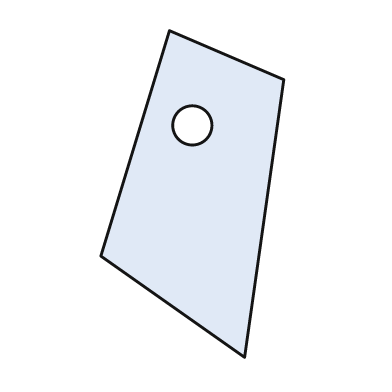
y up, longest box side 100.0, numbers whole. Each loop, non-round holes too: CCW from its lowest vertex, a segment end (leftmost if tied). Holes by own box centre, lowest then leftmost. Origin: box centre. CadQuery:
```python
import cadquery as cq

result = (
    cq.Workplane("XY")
    .moveTo(16.0, -50.0)
    .lineTo(28.0, 35.0)
    .lineTo(-7.0, 50.0)
    .lineTo(-28.0, -19.0)
    .close()
    .moveTo(0.0, 21.0)
    .circle(6.0)
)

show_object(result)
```